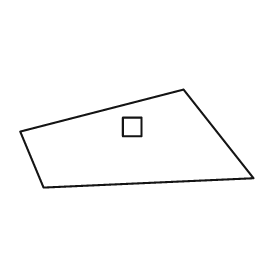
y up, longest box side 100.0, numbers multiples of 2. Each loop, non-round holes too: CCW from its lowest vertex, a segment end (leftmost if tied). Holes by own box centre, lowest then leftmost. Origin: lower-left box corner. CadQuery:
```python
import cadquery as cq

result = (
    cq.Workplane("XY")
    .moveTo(10.0, 0.0)
    .lineTo(100.0, 4.0)
    .lineTo(70.0, 42.0)
    .lineTo(0.0, 24.0)
    .close()
    .moveTo(44.0, 22.0)
    .lineTo(52.0, 22.0)
    .lineTo(52.0, 30.0)
    .lineTo(44.0, 30.0)
    .close()
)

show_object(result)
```